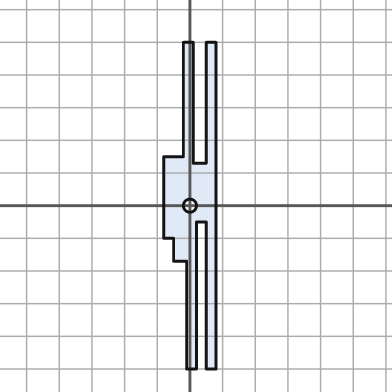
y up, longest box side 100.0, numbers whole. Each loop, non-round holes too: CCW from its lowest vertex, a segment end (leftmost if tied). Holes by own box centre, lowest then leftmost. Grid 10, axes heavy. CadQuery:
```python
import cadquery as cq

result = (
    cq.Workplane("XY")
    .moveTo(-1.0, -50.0)
    .lineTo(2.0, -50.0)
    .lineTo(2.0, -5.0)
    .lineTo(5.0, -5.0)
    .lineTo(5.0, -50.0)
    .lineTo(8.0, -50.0)
    .lineTo(8.0, 50.0)
    .lineTo(5.0, 50.0)
    .lineTo(5.0, 13.0)
    .lineTo(1.0, 13.0)
    .lineTo(1.0, 50.0)
    .lineTo(-2.0, 50.0)
    .lineTo(-2.0, 15.0)
    .lineTo(-8.0, 15.0)
    .lineTo(-8.0, -10.0)
    .lineTo(-5.0, -10.0)
    .lineTo(-5.0, -17.0)
    .lineTo(-1.0, -17.0)
    .close()
    .moveTo(0.0, 0.0)
    .circle(2.0)
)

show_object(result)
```